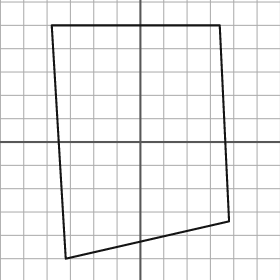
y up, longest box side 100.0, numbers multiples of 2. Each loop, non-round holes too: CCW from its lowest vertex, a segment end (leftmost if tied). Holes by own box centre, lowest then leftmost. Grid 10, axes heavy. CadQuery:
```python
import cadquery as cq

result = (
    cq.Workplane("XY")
    .moveTo(-32.0, -50.0)
    .lineTo(38.0, -34.0)
    .lineTo(34.0, 50.0)
    .lineTo(-38.0, 50.0)
    .close()
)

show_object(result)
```